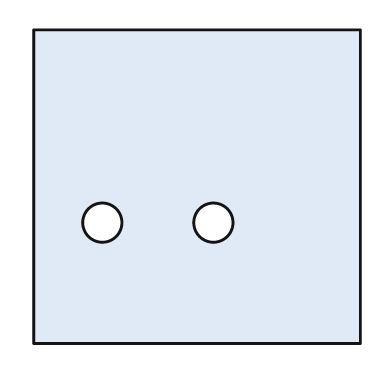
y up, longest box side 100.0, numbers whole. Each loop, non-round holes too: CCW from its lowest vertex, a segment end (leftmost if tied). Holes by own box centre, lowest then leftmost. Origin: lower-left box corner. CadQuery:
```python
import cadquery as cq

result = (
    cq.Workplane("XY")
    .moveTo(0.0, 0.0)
    .lineTo(100.0, 0.0)
    .lineTo(100.0, 96.0)
    .lineTo(0.0, 96.0)
    .close()
    .moveTo(21.0, 37.0)
    .circle(6.0)
    .moveTo(55.0, 37.0)
    .circle(6.0)
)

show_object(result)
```